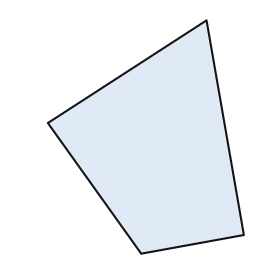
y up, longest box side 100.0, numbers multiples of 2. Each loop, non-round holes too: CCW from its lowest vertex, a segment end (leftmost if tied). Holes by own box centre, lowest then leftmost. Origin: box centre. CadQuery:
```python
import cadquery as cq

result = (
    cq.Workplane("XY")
    .moveTo(-2.0, -50.0)
    .lineTo(42.0, -42.0)
    .lineTo(26.0, 50.0)
    .lineTo(-42.0, 6.0)
    .close()
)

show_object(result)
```